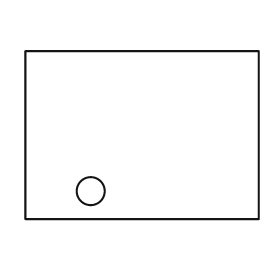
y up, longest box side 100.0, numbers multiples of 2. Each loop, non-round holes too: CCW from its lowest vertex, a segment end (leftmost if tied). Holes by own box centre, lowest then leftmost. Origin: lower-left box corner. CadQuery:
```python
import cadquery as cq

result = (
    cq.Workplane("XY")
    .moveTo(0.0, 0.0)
    .lineTo(100.0, 0.0)
    .lineTo(100.0, 72.0)
    .lineTo(0.0, 72.0)
    .close()
    .moveTo(28.0, 12.0)
    .circle(6.0)
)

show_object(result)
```